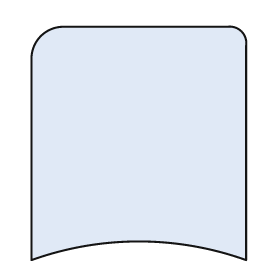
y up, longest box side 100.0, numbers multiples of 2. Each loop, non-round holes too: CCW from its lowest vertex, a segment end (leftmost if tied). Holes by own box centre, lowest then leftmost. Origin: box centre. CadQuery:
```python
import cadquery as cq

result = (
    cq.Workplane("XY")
    .moveTo(-46.0, -50.0)
    .threePointArc((0.0, -42.0), (46.0, -50.0))
    .lineTo(46.0, 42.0)
    .threePointArc((44.0, 48.0), (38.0, 50.0))
    .lineTo(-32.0, 50.0)
    .threePointArc((-42.0, 46.0), (-46.0, 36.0))
    .close()
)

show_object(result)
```